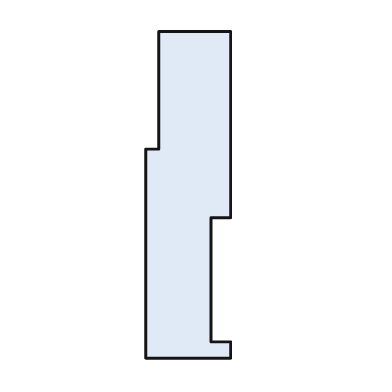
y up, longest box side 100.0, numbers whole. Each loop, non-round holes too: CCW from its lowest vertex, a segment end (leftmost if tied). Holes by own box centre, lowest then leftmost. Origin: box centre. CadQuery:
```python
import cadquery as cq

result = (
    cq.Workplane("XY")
    .moveTo(-13.0, -50.0)
    .lineTo(13.0, -50.0)
    .lineTo(13.0, -45.0)
    .lineTo(7.0, -45.0)
    .lineTo(7.0, -7.0)
    .lineTo(13.0, -7.0)
    .lineTo(13.0, 50.0)
    .lineTo(-9.0, 50.0)
    .lineTo(-9.0, 14.0)
    .lineTo(-13.0, 14.0)
    .close()
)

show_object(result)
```